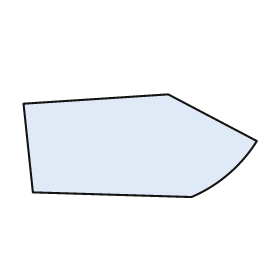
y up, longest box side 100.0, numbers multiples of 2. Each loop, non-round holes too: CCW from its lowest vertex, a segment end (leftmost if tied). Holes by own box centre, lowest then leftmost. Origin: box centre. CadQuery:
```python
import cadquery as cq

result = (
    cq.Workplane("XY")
    .moveTo(22.0, -22.0)
    .threePointArc((38.0, -12.0), (50.0, 2.0))
    .lineTo(12.0, 22.0)
    .lineTo(-50.0, 18.0)
    .lineTo(-46.0, -20.0)
    .close()
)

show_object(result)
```